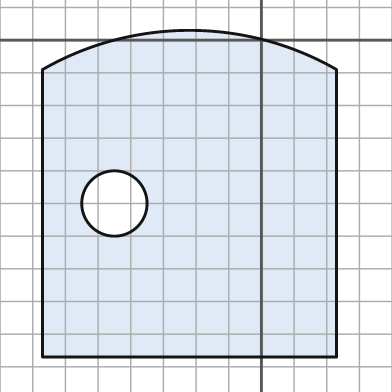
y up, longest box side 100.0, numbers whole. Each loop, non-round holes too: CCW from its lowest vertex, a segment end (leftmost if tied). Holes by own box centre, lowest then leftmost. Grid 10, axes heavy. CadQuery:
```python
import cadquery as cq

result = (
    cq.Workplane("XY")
    .moveTo(-67.0, -97.0)
    .lineTo(23.0, -97.0)
    .lineTo(23.0, -9.0)
    .threePointArc((-22.0, 3.0), (-67.0, -9.0))
    .close()
    .moveTo(-45.0, -50.0)
    .circle(10.0)
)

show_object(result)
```